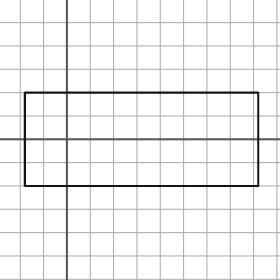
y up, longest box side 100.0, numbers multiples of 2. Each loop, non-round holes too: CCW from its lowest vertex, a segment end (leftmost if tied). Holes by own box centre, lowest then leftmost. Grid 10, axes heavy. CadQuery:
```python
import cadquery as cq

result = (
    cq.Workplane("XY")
    .moveTo(-18.0, -20.0)
    .lineTo(82.0, -20.0)
    .lineTo(82.0, 20.0)
    .lineTo(-18.0, 20.0)
    .close()
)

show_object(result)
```